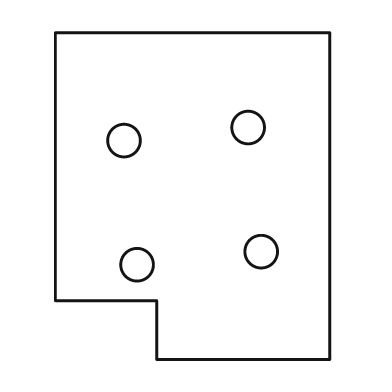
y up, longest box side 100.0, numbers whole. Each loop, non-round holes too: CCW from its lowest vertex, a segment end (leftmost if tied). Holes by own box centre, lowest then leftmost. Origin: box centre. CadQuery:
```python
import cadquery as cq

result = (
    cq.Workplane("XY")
    .moveTo(-11.0, -50.0)
    .lineTo(42.0, -50.0)
    .lineTo(42.0, 50.0)
    .lineTo(-42.0, 50.0)
    .lineTo(-42.0, -32.0)
    .lineTo(-11.0, -32.0)
    .close()
    .moveTo(-17.0, -21.0)
    .circle(5.0)
    .moveTo(21.0, -17.0)
    .circle(5.0)
    .moveTo(-21.0, 17.0)
    .circle(5.0)
    .moveTo(17.0, 21.0)
    .circle(5.0)
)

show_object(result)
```